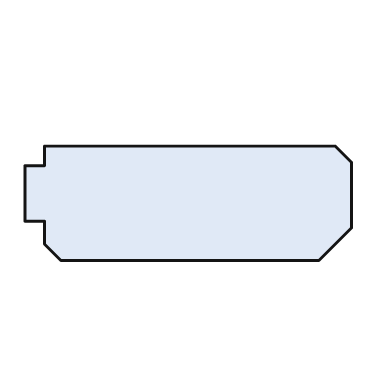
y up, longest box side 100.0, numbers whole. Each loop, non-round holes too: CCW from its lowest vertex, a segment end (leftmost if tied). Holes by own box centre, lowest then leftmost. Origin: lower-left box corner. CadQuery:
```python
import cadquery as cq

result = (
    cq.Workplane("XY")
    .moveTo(11.0, 0.0)
    .lineTo(90.0, 0.0)
    .lineTo(100.0, 10.0)
    .lineTo(100.0, 30.0)
    .lineTo(95.0, 35.0)
    .lineTo(6.0, 35.0)
    .lineTo(6.0, 29.0)
    .lineTo(0.0, 29.0)
    .lineTo(0.0, 12.0)
    .lineTo(6.0, 12.0)
    .lineTo(6.0, 5.0)
    .close()
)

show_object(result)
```